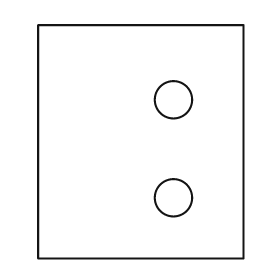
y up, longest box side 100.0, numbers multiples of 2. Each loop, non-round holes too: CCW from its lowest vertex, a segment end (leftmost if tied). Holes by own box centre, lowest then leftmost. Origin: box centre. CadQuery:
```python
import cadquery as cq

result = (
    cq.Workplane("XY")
    .moveTo(-44.0, -50.0)
    .lineTo(44.0, -50.0)
    .lineTo(44.0, 50.0)
    .lineTo(-44.0, 50.0)
    .close()
    .moveTo(14.0, -24.0)
    .circle(8.0)
    .moveTo(14.0, 18.0)
    .circle(8.0)
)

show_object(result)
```